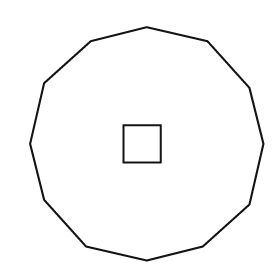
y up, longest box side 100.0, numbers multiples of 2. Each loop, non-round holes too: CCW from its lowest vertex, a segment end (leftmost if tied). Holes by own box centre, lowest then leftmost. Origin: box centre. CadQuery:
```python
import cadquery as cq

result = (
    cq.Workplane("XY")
    .moveTo(0.0, -50.0)
    .lineTo(24.0, -44.0)
    .lineTo(44.0, -26.0)
    .lineTo(50.0, 0.0)
    .lineTo(44.0, 24.0)
    .lineTo(26.0, 44.0)
    .lineTo(0.0, 50.0)
    .lineTo(-24.0, 44.0)
    .lineTo(-44.0, 26.0)
    .lineTo(-50.0, 0.0)
    .lineTo(-44.0, -24.0)
    .lineTo(-26.0, -44.0)
    .close()
    .moveTo(-10.0, -8.0)
    .lineTo(6.0, -8.0)
    .lineTo(6.0, 8.0)
    .lineTo(-10.0, 8.0)
    .close()
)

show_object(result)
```